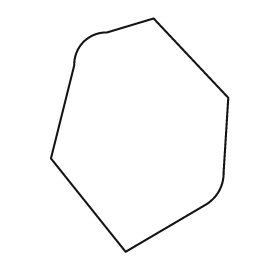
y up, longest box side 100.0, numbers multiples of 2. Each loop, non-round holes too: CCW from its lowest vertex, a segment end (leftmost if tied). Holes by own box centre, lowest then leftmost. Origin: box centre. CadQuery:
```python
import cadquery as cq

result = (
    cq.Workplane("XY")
    .moveTo(-6.0, -50.0)
    .lineTo(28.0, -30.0)
    .threePointArc((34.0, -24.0), (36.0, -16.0))
    .lineTo(38.0, 16.0)
    .lineTo(6.0, 50.0)
    .lineTo(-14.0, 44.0)
    .threePointArc((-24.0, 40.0), (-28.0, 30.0))
    .lineTo(-38.0, -10.0)
    .close()
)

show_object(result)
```